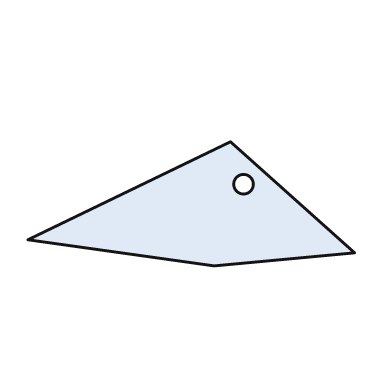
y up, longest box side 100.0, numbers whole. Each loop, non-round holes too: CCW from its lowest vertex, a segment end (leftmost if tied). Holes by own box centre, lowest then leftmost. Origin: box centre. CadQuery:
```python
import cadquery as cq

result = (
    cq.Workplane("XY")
    .moveTo(7.0, -19.0)
    .lineTo(50.0, -15.0)
    .lineTo(12.0, 19.0)
    .lineTo(-50.0, -11.0)
    .close()
    .moveTo(16.0, 6.0)
    .circle(3.0)
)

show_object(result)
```